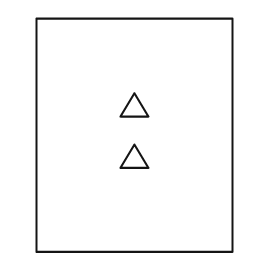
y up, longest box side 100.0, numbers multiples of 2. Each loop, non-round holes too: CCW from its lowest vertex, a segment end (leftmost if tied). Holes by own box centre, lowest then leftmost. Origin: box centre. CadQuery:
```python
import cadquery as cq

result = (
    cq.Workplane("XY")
    .moveTo(-42.0, -50.0)
    .lineTo(42.0, -50.0)
    .lineTo(42.0, 50.0)
    .lineTo(-42.0, 50.0)
    .close()
    .moveTo(-6.0, -14.0)
    .lineTo(6.0, -14.0)
    .lineTo(0.0, -4.0)
    .close()
    .moveTo(-6.0, 8.0)
    .lineTo(6.0, 8.0)
    .lineTo(0.0, 18.0)
    .close()
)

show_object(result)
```